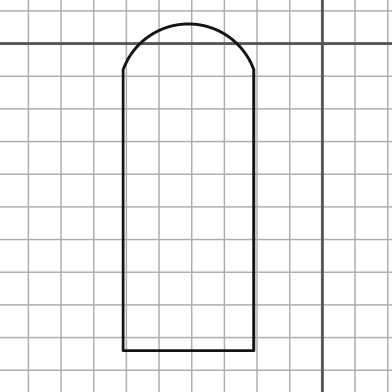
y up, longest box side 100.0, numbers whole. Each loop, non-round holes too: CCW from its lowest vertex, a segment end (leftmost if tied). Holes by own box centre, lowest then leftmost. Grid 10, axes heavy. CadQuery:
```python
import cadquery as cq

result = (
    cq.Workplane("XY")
    .moveTo(-61.0, -94.0)
    .lineTo(-21.0, -94.0)
    .lineTo(-21.0, -8.0)
    .threePointArc((-41.0, 6.0), (-61.0, -8.0))
    .close()
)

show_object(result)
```